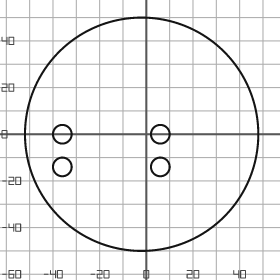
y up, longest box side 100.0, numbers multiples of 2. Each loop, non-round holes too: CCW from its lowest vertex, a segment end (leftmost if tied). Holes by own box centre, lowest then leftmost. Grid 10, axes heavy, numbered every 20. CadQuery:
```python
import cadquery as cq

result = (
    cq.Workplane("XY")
    .moveTo(-2.0, 0.0)
    .circle(50.0)
    .moveTo(-36.0, -14.0)
    .circle(4.0)
    .moveTo(6.0, -14.0)
    .circle(4.0)
    .moveTo(-36.0, 0.0)
    .circle(4.0)
    .moveTo(6.0, 0.0)
    .circle(4.0)
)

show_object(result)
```